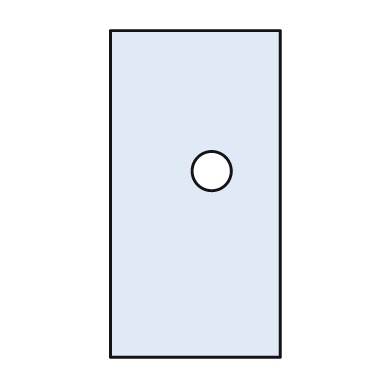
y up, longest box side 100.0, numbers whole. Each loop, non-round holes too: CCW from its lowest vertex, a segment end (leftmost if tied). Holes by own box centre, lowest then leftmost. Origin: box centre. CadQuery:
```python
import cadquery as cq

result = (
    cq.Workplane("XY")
    .moveTo(-26.0, -50.0)
    .lineTo(26.0, -50.0)
    .lineTo(26.0, 50.0)
    .lineTo(-26.0, 50.0)
    .close()
    .moveTo(5.0, 7.0)
    .circle(6.0)
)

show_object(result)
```